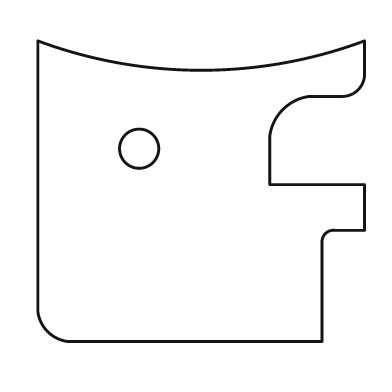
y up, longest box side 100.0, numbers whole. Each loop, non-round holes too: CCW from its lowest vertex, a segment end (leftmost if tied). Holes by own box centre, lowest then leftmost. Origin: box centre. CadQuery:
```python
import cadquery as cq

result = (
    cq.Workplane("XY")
    .moveTo(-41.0, -46.0)
    .lineTo(37.0, -46.0)
    .lineTo(37.0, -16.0)
    .threePointArc((38.0, -13.0), (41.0, -12.0))
    .lineTo(50.0, -12.0)
    .lineTo(50.0, 2.0)
    .lineTo(21.0, 2.0)
    .lineTo(21.0, 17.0)
    .threePointArc((25.0, 25.0), (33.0, 29.0))
    .lineTo(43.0, 29.0)
    .threePointArc((48.0, 31.0), (50.0, 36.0))
    .lineTo(50.0, 46.0)
    .threePointArc((0.0, 37.0), (-50.0, 46.0))
    .lineTo(-50.0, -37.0)
    .threePointArc((-47.0, -43.0), (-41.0, -46.0))
    .close()
    .moveTo(-19.0, 13.0)
    .circle(6.0)
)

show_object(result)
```